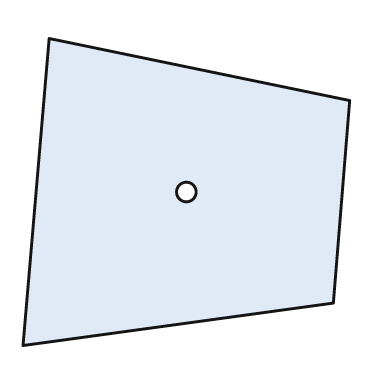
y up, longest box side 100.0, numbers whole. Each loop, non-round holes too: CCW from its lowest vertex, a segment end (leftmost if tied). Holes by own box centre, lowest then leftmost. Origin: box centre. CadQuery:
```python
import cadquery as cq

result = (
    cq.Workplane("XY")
    .moveTo(-50.0, -47.0)
    .lineTo(45.0, -34.0)
    .lineTo(50.0, 28.0)
    .lineTo(-42.0, 47.0)
    .close()
    .moveTo(0.0, 0.0)
    .circle(3.0)
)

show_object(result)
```